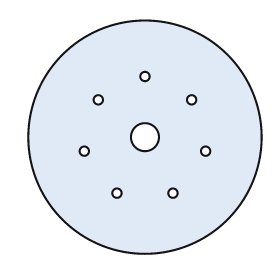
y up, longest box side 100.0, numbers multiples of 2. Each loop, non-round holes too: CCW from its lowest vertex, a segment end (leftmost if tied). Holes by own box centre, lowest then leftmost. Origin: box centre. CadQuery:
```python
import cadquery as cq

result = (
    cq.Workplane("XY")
    .moveTo(0.0, 0.0)
    .circle(50.0)
    .moveTo(-12.0, -24.0)
    .circle(2.0)
    .moveTo(12.0, -24.0)
    .circle(2.0)
    .moveTo(-26.0, -6.0)
    .circle(2.0)
    .moveTo(26.0, -6.0)
    .circle(2.0)
    .moveTo(0.0, 0.0)
    .circle(6.0)
    .moveTo(-20.0, 16.0)
    .circle(2.0)
    .moveTo(20.0, 16.0)
    .circle(2.0)
    .moveTo(0.0, 26.0)
    .circle(2.0)
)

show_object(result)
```